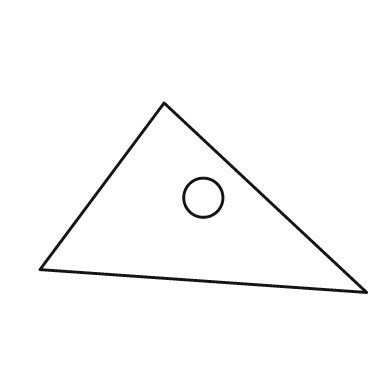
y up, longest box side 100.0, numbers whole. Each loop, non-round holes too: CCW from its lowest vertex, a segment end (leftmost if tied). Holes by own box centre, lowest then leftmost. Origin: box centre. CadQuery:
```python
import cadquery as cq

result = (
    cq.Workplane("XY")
    .moveTo(50.0, -29.0)
    .lineTo(-12.0, 29.0)
    .lineTo(-50.0, -22.0)
    .close()
    .moveTo(0.0, 0.0)
    .circle(6.0)
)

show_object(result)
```